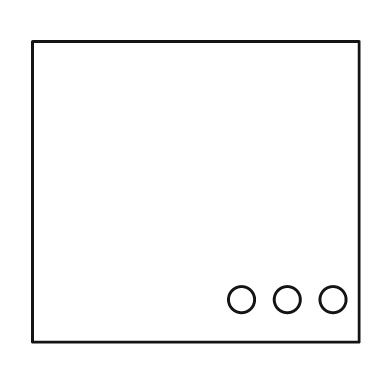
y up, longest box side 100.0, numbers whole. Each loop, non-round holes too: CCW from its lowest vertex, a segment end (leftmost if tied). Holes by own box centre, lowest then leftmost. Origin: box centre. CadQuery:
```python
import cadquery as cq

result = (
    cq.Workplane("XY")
    .moveTo(-50.0, -46.0)
    .lineTo(50.0, -46.0)
    .lineTo(50.0, 46.0)
    .lineTo(-50.0, 46.0)
    .close()
    .moveTo(14.0, -33.0)
    .circle(4.0)
    .moveTo(28.0, -33.0)
    .circle(4.0)
    .moveTo(42.0, -33.0)
    .circle(4.0)
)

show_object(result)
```